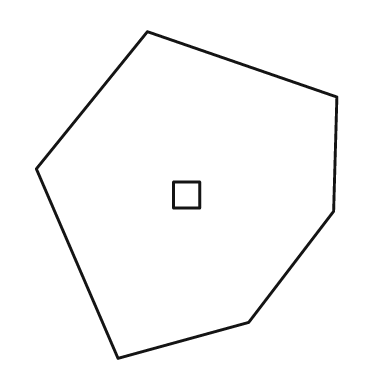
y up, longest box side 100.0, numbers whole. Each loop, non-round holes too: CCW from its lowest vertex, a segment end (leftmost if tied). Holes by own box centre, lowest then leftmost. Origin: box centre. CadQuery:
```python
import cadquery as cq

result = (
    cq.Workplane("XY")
    .moveTo(-21.0, -50.0)
    .lineTo(19.0, -39.0)
    .lineTo(45.0, -5.0)
    .lineTo(46.0, 30.0)
    .lineTo(-12.0, 50.0)
    .lineTo(-46.0, 8.0)
    .close()
    .moveTo(-4.0, -4.0)
    .lineTo(4.0, -4.0)
    .lineTo(4.0, 4.0)
    .lineTo(-4.0, 4.0)
    .close()
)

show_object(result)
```